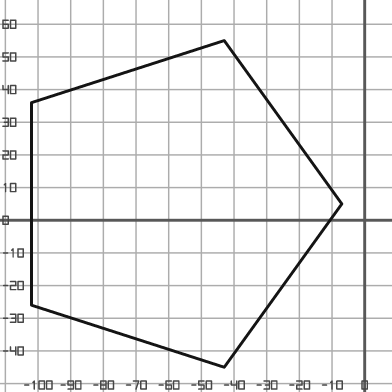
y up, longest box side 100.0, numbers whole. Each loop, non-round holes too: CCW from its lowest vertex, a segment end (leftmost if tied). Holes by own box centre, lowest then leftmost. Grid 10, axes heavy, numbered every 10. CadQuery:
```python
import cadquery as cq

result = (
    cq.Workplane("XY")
    .moveTo(-43.0, -45.0)
    .lineTo(-7.0, 5.0)
    .lineTo(-43.0, 55.0)
    .lineTo(-102.0, 36.0)
    .lineTo(-102.0, -26.0)
    .close()
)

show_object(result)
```